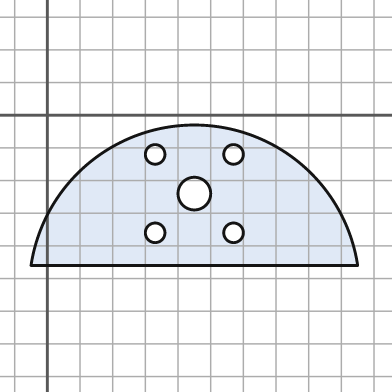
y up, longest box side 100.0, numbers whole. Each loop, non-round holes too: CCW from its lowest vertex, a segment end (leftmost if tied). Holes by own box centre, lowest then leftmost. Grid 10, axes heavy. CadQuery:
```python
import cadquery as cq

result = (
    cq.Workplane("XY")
    .moveTo(-5.0, -46.0)
    .lineTo(95.0, -46.0)
    .threePointArc((45.0, -3.0), (-5.0, -46.0))
    .close()
    .moveTo(33.0, -36.0)
    .circle(3.0)
    .moveTo(57.0, -36.0)
    .circle(3.0)
    .moveTo(45.0, -24.0)
    .circle(5.0)
    .moveTo(33.0, -12.0)
    .circle(3.0)
    .moveTo(57.0, -12.0)
    .circle(3.0)
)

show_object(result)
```